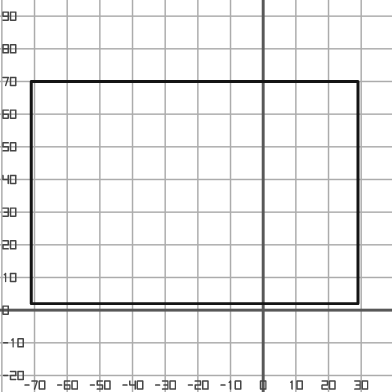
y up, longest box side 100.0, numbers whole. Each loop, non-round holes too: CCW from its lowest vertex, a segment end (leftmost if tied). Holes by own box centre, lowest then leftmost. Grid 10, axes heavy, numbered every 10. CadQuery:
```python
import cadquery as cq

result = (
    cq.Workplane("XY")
    .moveTo(-71.0, 2.0)
    .lineTo(29.0, 2.0)
    .lineTo(29.0, 70.0)
    .lineTo(-71.0, 70.0)
    .close()
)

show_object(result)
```